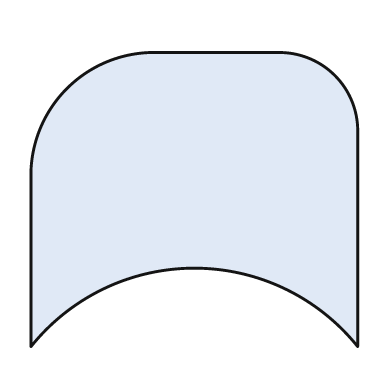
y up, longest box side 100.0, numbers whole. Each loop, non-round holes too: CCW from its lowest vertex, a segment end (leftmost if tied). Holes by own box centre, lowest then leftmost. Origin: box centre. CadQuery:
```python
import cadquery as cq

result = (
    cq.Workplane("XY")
    .moveTo(-50.0, -45.0)
    .threePointArc((0.0, -21.0), (50.0, -45.0))
    .lineTo(50.0, 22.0)
    .threePointArc((43.0, 38.0), (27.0, 45.0))
    .lineTo(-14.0, 45.0)
    .threePointArc((-39.0, 34.0), (-50.0, 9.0))
    .close()
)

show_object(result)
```